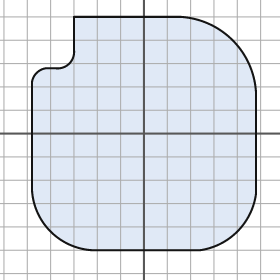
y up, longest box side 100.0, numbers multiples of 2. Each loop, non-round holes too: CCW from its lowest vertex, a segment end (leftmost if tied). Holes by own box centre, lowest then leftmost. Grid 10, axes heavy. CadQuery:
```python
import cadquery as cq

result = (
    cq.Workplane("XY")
    .moveTo(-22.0, -50.0)
    .lineTo(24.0, -50.0)
    .threePointArc((40.0, -42.0), (48.0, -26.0))
    .lineTo(48.0, 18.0)
    .threePointArc((38.0, 40.0), (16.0, 50.0))
    .lineTo(-30.0, 50.0)
    .lineTo(-30.0, 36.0)
    .threePointArc((-32.0, 30.0), (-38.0, 28.0))
    .lineTo(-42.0, 28.0)
    .threePointArc((-46.0, 26.0), (-48.0, 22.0))
    .lineTo(-48.0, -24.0)
    .threePointArc((-40.0, -42.0), (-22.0, -50.0))
    .close()
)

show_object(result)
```